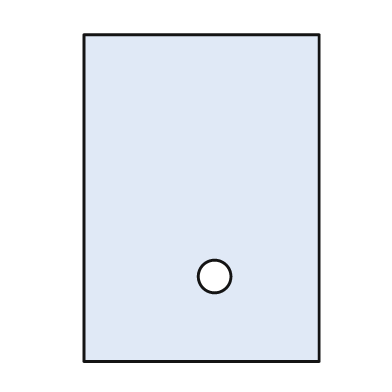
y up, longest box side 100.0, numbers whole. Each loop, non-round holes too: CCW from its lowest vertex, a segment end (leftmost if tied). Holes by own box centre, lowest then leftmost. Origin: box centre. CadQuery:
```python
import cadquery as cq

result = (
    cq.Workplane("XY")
    .moveTo(-36.0, -50.0)
    .lineTo(36.0, -50.0)
    .lineTo(36.0, 50.0)
    .lineTo(-36.0, 50.0)
    .close()
    .moveTo(4.0, -24.0)
    .circle(5.0)
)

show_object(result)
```